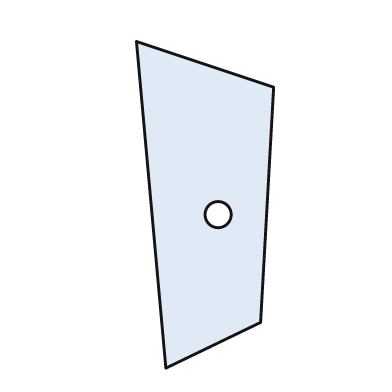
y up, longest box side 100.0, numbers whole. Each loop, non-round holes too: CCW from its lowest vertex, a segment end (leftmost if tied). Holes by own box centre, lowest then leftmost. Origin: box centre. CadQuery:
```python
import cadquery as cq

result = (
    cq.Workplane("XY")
    .moveTo(-12.0, -50.0)
    .lineTo(17.0, -36.0)
    .lineTo(21.0, 36.0)
    .lineTo(-21.0, 50.0)
    .close()
    .moveTo(4.0, -3.0)
    .circle(4.0)
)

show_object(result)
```